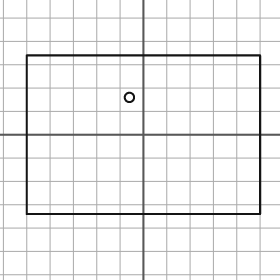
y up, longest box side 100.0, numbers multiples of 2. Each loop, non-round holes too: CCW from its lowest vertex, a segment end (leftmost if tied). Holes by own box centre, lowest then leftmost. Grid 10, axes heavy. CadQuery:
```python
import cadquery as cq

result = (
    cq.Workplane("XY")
    .moveTo(-50.0, -34.0)
    .lineTo(50.0, -34.0)
    .lineTo(50.0, 34.0)
    .lineTo(-50.0, 34.0)
    .close()
    .moveTo(-6.0, 16.0)
    .circle(2.0)
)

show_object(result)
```